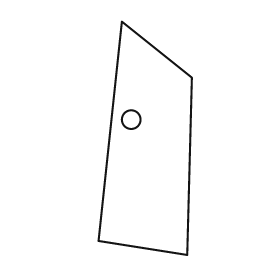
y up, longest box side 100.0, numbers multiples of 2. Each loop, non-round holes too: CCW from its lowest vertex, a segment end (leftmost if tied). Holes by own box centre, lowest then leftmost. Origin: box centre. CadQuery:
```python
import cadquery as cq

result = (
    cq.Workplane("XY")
    .moveTo(18.0, -50.0)
    .lineTo(20.0, 26.0)
    .lineTo(-10.0, 50.0)
    .lineTo(-20.0, -44.0)
    .close()
    .moveTo(-6.0, 8.0)
    .circle(4.0)
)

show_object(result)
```